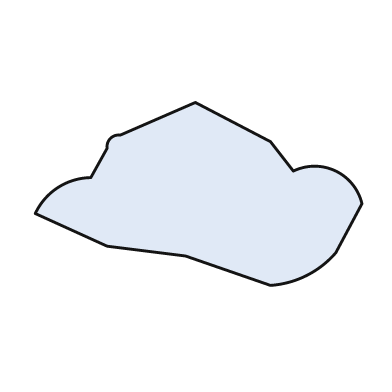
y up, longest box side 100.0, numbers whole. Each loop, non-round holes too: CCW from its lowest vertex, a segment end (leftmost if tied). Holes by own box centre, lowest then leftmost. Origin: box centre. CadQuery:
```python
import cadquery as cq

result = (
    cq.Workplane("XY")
    .moveTo(22.0, -28.0)
    .threePointArc((33.0, -25.0), (42.0, -18.0))
    .lineTo(50.0, -3.0)
    .threePointArc((42.0, 7.0), (29.0, 7.0))
    .lineTo(22.0, 16.0)
    .lineTo(-1.0, 28.0)
    .lineTo(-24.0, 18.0)
    .threePointArc((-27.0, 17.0), (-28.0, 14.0))
    .lineTo(-33.0, 5.0)
    .threePointArc((-43.0, 2.0), (-50.0, -6.0))
    .lineTo(-28.0, -16.0)
    .lineTo(-4.0, -19.0)
    .close()
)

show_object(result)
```